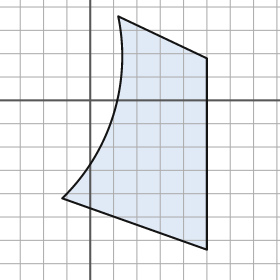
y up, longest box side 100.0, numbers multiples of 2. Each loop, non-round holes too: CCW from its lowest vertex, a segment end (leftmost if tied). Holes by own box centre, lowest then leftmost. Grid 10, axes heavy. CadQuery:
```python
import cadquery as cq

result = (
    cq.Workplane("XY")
    .moveTo(50.0, -64.0)
    .lineTo(50.0, 18.0)
    .lineTo(12.0, 36.0)
    .threePointArc((10.0, -6.0), (-12.0, -42.0))
    .close()
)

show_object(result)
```